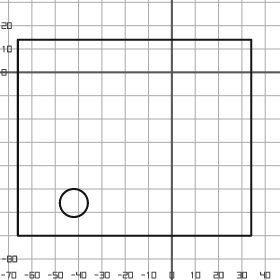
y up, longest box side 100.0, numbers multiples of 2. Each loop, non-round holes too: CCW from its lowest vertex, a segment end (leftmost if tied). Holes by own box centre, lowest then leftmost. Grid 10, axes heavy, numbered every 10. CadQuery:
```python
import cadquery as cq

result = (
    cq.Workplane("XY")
    .moveTo(-66.0, -70.0)
    .lineTo(34.0, -70.0)
    .lineTo(34.0, 14.0)
    .lineTo(-66.0, 14.0)
    .close()
    .moveTo(-42.0, -56.0)
    .circle(6.0)
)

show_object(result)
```